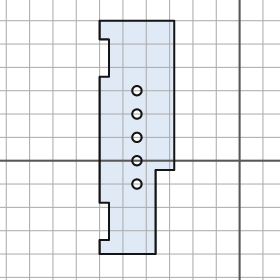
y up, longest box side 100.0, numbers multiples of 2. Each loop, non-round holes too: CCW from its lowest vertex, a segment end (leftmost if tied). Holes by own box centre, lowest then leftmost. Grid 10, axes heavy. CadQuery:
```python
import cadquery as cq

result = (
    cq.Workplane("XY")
    .moveTo(-60.0, -40.0)
    .lineTo(-36.0, -40.0)
    .lineTo(-36.0, -4.0)
    .lineTo(-28.0, -4.0)
    .lineTo(-28.0, 60.0)
    .lineTo(-60.0, 60.0)
    .lineTo(-60.0, 52.0)
    .lineTo(-56.0, 52.0)
    .lineTo(-56.0, 36.0)
    .lineTo(-60.0, 36.0)
    .lineTo(-60.0, -18.0)
    .lineTo(-56.0, -18.0)
    .lineTo(-56.0, -34.0)
    .lineTo(-60.0, -34.0)
    .close()
    .moveTo(-44.0, -10.0)
    .circle(2.0)
    .moveTo(-44.0, 0.0)
    .circle(2.0)
    .moveTo(-44.0, 10.0)
    .circle(2.0)
    .moveTo(-44.0, 20.0)
    .circle(2.0)
    .moveTo(-44.0, 30.0)
    .circle(2.0)
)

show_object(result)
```